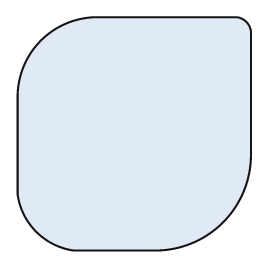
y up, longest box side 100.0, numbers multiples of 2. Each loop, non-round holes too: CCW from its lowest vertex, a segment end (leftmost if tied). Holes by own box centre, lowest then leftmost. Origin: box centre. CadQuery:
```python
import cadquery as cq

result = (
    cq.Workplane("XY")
    .moveTo(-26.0, -50.0)
    .lineTo(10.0, -50.0)
    .threePointArc((38.0, -38.0), (50.0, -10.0))
    .lineTo(50.0, 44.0)
    .threePointArc((48.0, 48.0), (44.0, 50.0))
    .lineTo(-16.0, 50.0)
    .threePointArc((-40.0, 40.0), (-50.0, 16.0))
    .lineTo(-50.0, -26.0)
    .threePointArc((-42.0, -42.0), (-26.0, -50.0))
    .close()
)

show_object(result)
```